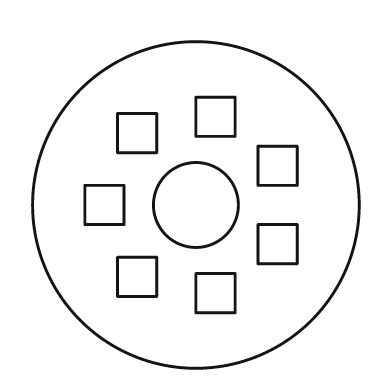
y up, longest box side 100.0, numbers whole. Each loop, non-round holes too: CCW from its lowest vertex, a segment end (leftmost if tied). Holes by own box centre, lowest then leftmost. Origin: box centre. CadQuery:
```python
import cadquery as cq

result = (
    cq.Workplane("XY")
    .moveTo(0.0, 0.0)
    .circle(50.0)
    .moveTo(0.0, -33.0)
    .lineTo(12.0, -33.0)
    .lineTo(12.0, -21.0)
    .lineTo(0.0, -21.0)
    .close()
    .moveTo(-24.0, -28.0)
    .lineTo(-12.0, -28.0)
    .lineTo(-12.0, -16.0)
    .lineTo(-24.0, -16.0)
    .close()
    .moveTo(19.0, -18.0)
    .lineTo(31.0, -18.0)
    .lineTo(31.0, -6.0)
    .lineTo(19.0, -6.0)
    .close()
    .moveTo(-34.0, -6.0)
    .lineTo(-22.0, -6.0)
    .lineTo(-22.0, 6.0)
    .lineTo(-34.0, 6.0)
    .close()
    .moveTo(0.0, 0.0)
    .circle(13.0)
    .moveTo(19.0, 6.0)
    .lineTo(31.0, 6.0)
    .lineTo(31.0, 18.0)
    .lineTo(19.0, 18.0)
    .close()
    .moveTo(-24.0, 16.0)
    .lineTo(-12.0, 16.0)
    .lineTo(-12.0, 28.0)
    .lineTo(-24.0, 28.0)
    .close()
    .moveTo(0.0, 21.0)
    .lineTo(12.0, 21.0)
    .lineTo(12.0, 33.0)
    .lineTo(0.0, 33.0)
    .close()
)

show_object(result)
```